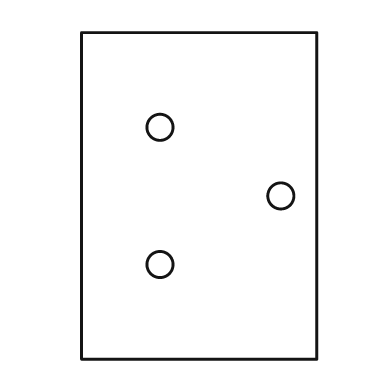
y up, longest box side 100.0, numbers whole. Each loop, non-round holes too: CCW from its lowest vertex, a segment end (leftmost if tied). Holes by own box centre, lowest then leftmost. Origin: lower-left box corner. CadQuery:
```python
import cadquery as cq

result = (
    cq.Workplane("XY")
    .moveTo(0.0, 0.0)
    .lineTo(72.0, 0.0)
    .lineTo(72.0, 100.0)
    .lineTo(0.0, 100.0)
    .close()
    .moveTo(24.0, 29.0)
    .circle(4.0)
    .moveTo(61.0, 50.0)
    .circle(4.0)
    .moveTo(24.0, 71.0)
    .circle(4.0)
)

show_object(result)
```